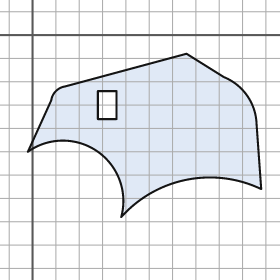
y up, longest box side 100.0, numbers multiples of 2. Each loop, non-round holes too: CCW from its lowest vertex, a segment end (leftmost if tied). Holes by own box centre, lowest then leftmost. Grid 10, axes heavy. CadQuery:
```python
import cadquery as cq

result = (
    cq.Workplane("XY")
    .moveTo(38.0, -78.0)
    .threePointArc((66.0, -62.0), (98.0, -66.0))
    .lineTo(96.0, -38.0)
    .threePointArc((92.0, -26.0), (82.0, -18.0))
    .lineTo(66.0, -8.0)
    .lineTo(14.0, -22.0)
    .threePointArc((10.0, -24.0), (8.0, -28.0))
    .lineTo(-2.0, -50.0)
    .threePointArc((28.0, -50.0), (38.0, -78.0))
    .close()
    .moveTo(28.0, -36.0)
    .lineTo(36.0, -36.0)
    .lineTo(36.0, -24.0)
    .lineTo(28.0, -24.0)
    .close()
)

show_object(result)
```